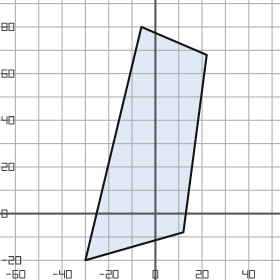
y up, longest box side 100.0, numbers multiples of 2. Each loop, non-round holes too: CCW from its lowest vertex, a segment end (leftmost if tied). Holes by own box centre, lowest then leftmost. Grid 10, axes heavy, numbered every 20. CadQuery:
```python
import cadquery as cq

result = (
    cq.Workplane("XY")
    .moveTo(-30.0, -20.0)
    .lineTo(12.0, -8.0)
    .lineTo(22.0, 68.0)
    .lineTo(-6.0, 80.0)
    .close()
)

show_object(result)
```